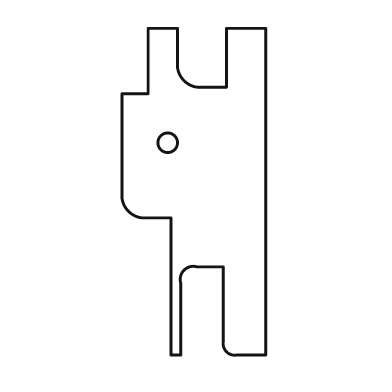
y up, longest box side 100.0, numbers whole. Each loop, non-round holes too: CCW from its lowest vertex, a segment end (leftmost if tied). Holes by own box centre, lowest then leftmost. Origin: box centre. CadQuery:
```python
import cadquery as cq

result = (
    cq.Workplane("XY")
    .moveTo(-7.0, -50.0)
    .lineTo(-4.0, -50.0)
    .lineTo(-4.0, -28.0)
    .threePointArc((-3.0, -24.0), (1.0, -23.0))
    .lineTo(9.0, -23.0)
    .lineTo(9.0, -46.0)
    .threePointArc((10.0, -49.0), (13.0, -50.0))
    .lineTo(22.0, -50.0)
    .lineTo(22.0, 50.0)
    .lineTo(10.0, 50.0)
    .lineTo(10.0, 32.0)
    .lineTo(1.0, 32.0)
    .threePointArc((-3.0, 34.0), (-5.0, 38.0))
    .lineTo(-5.0, 50.0)
    .lineTo(-14.0, 50.0)
    .lineTo(-14.0, 30.0)
    .lineTo(-22.0, 30.0)
    .lineTo(-22.0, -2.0)
    .threePointArc((-20.0, -6.0), (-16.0, -8.0))
    .lineTo(-7.0, -8.0)
    .close()
    .moveTo(-8.0, 15.0)
    .circle(3.0)
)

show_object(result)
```